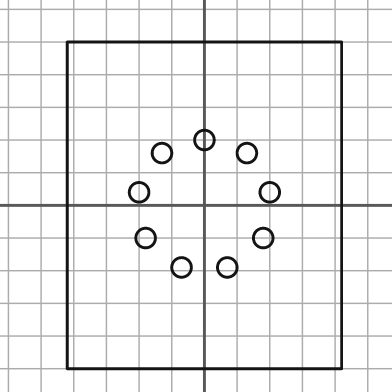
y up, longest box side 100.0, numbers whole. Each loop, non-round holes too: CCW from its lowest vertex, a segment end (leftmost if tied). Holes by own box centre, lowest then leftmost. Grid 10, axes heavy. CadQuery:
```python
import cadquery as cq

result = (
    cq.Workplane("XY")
    .moveTo(-42.0, -50.0)
    .lineTo(42.0, -50.0)
    .lineTo(42.0, 50.0)
    .lineTo(-42.0, 50.0)
    .close()
    .moveTo(-7.0, -19.0)
    .circle(3.0)
    .moveTo(7.0, -19.0)
    .circle(3.0)
    .moveTo(-18.0, -10.0)
    .circle(3.0)
    .moveTo(18.0, -10.0)
    .circle(3.0)
    .moveTo(-20.0, 4.0)
    .circle(3.0)
    .moveTo(20.0, 4.0)
    .circle(3.0)
    .moveTo(-13.0, 16.0)
    .circle(3.0)
    .moveTo(13.0, 16.0)
    .circle(3.0)
    .moveTo(0.0, 20.0)
    .circle(3.0)
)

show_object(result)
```